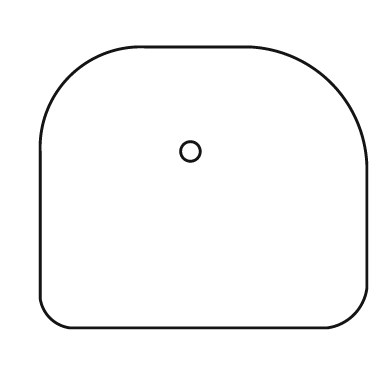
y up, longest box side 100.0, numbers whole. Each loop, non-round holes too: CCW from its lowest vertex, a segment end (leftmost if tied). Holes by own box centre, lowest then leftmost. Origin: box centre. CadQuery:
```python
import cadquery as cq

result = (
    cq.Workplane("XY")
    .moveTo(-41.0, -43.0)
    .lineTo(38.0, -43.0)
    .threePointArc((46.0, -39.0), (50.0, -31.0))
    .lineTo(50.0, 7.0)
    .threePointArc((39.0, 32.0), (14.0, 43.0))
    .lineTo(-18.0, 43.0)
    .threePointArc((-41.0, 34.0), (-50.0, 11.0))
    .lineTo(-50.0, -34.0)
    .threePointArc((-47.0, -40.0), (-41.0, -43.0))
    .close()
    .moveTo(-4.0, 11.0)
    .circle(3.0)
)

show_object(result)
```